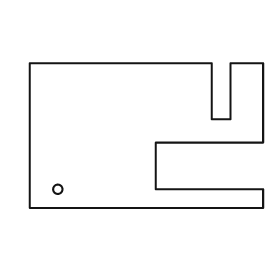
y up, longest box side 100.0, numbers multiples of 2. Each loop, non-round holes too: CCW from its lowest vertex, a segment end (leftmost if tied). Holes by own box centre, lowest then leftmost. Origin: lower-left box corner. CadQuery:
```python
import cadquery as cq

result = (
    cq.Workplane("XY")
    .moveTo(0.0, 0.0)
    .lineTo(100.0, 0.0)
    .lineTo(100.0, 8.0)
    .lineTo(54.0, 8.0)
    .lineTo(54.0, 28.0)
    .lineTo(100.0, 28.0)
    .lineTo(100.0, 62.0)
    .lineTo(86.0, 62.0)
    .lineTo(86.0, 38.0)
    .lineTo(78.0, 38.0)
    .lineTo(78.0, 62.0)
    .lineTo(0.0, 62.0)
    .close()
    .moveTo(12.0, 8.0)
    .circle(2.0)
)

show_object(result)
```